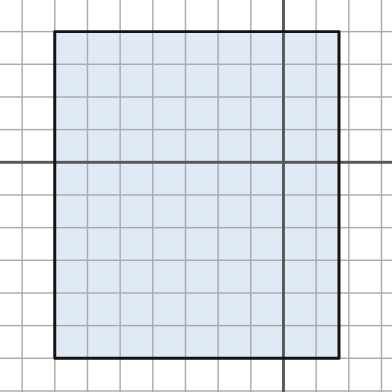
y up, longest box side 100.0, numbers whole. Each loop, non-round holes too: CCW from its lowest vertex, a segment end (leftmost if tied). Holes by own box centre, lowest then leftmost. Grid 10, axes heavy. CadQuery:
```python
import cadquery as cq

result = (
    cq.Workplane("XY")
    .moveTo(-70.0, -60.0)
    .lineTo(17.0, -60.0)
    .lineTo(17.0, 40.0)
    .lineTo(-70.0, 40.0)
    .close()
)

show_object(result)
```